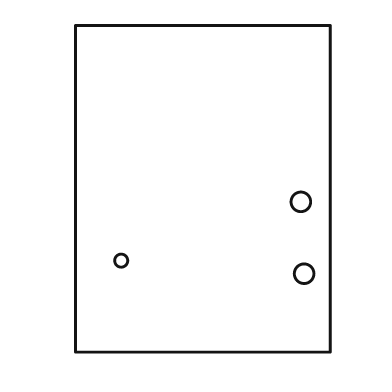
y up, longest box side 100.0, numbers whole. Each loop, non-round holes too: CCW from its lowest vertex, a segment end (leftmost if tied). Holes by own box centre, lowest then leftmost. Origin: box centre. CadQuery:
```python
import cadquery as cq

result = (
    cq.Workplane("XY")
    .moveTo(-39.0, -50.0)
    .lineTo(39.0, -50.0)
    .lineTo(39.0, 50.0)
    .lineTo(-39.0, 50.0)
    .close()
    .moveTo(31.0, -26.0)
    .circle(3.0)
    .moveTo(-25.0, -22.0)
    .circle(2.0)
    .moveTo(30.0, -4.0)
    .circle(3.0)
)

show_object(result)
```